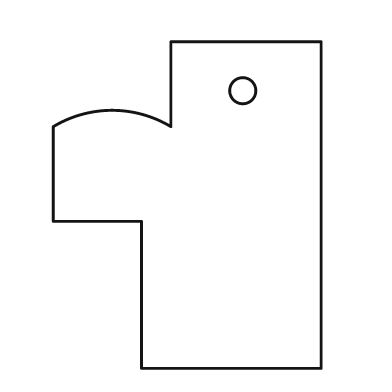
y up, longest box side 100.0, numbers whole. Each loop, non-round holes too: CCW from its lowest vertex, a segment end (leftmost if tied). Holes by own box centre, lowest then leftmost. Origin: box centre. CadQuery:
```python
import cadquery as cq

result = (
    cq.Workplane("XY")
    .moveTo(-14.0, -50.0)
    .lineTo(41.0, -50.0)
    .lineTo(41.0, 50.0)
    .lineTo(-5.0, 50.0)
    .lineTo(-5.0, 24.0)
    .threePointArc((-23.0, 29.0), (-41.0, 24.0))
    .lineTo(-41.0, -5.0)
    .lineTo(-14.0, -5.0)
    .close()
    .moveTo(17.0, 35.0)
    .circle(4.0)
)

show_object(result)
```